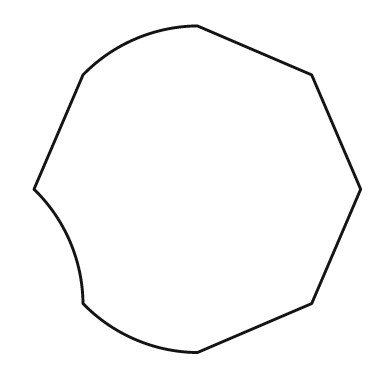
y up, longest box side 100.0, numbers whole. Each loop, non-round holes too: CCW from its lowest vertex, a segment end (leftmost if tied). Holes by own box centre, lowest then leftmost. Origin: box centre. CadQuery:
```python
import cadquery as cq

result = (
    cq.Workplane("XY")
    .moveTo(0.0, -50.0)
    .lineTo(35.0, -35.0)
    .lineTo(50.0, 0.0)
    .lineTo(35.0, 35.0)
    .lineTo(0.0, 50.0)
    .threePointArc((-19.0, 46.0), (-35.0, 35.0))
    .lineTo(-50.0, 0.0)
    .threePointArc((-39.0, -16.0), (-35.0, -35.0))
    .threePointArc((-19.0, -46.0), (0.0, -50.0))
    .close()
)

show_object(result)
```